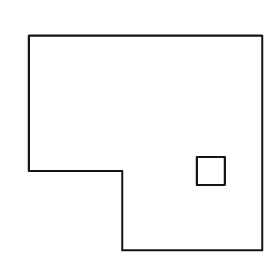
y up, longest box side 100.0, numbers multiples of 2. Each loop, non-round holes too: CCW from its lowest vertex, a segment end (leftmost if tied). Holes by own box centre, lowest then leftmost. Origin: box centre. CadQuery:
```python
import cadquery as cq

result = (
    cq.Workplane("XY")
    .moveTo(-10.0, -46.0)
    .lineTo(50.0, -46.0)
    .lineTo(50.0, 46.0)
    .lineTo(-50.0, 46.0)
    .lineTo(-50.0, -12.0)
    .lineTo(-10.0, -12.0)
    .close()
    .moveTo(22.0, -18.0)
    .lineTo(34.0, -18.0)
    .lineTo(34.0, -6.0)
    .lineTo(22.0, -6.0)
    .close()
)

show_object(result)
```